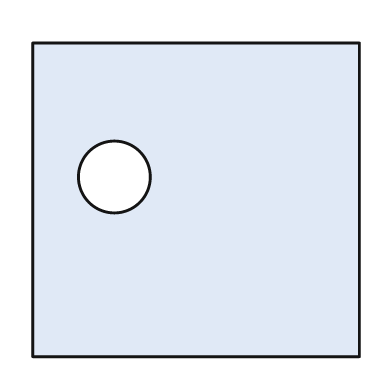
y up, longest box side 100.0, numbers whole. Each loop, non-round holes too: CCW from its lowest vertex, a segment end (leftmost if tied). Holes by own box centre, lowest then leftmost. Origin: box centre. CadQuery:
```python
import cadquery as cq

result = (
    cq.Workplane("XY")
    .moveTo(-50.0, -48.0)
    .lineTo(50.0, -48.0)
    .lineTo(50.0, 48.0)
    .lineTo(-50.0, 48.0)
    .close()
    .moveTo(-25.0, 7.0)
    .circle(11.0)
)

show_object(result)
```